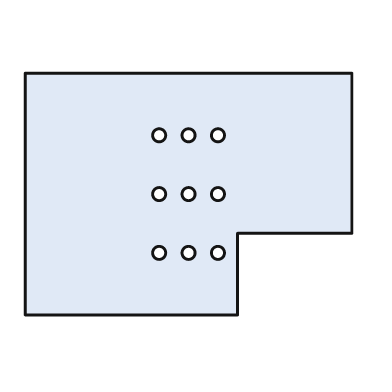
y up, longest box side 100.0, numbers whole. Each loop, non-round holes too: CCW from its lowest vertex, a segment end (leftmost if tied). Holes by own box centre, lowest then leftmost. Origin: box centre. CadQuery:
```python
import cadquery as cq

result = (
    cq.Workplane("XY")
    .moveTo(-50.0, -37.0)
    .lineTo(15.0, -37.0)
    .lineTo(15.0, -12.0)
    .lineTo(50.0, -12.0)
    .lineTo(50.0, 37.0)
    .lineTo(-50.0, 37.0)
    .close()
    .moveTo(-9.0, -18.0)
    .circle(2.0)
    .moveTo(0.0, -18.0)
    .circle(2.0)
    .moveTo(9.0, -18.0)
    .circle(2.0)
    .moveTo(-9.0, 0.0)
    .circle(2.0)
    .moveTo(0.0, 0.0)
    .circle(2.0)
    .moveTo(9.0, 0.0)
    .circle(2.0)
    .moveTo(-9.0, 18.0)
    .circle(2.0)
    .moveTo(0.0, 18.0)
    .circle(2.0)
    .moveTo(9.0, 18.0)
    .circle(2.0)
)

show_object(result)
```